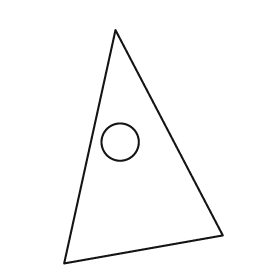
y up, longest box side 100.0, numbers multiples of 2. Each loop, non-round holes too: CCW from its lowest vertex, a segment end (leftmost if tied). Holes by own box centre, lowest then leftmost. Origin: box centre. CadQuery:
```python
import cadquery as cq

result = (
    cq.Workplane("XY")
    .moveTo(-34.0, -50.0)
    .lineTo(34.0, -38.0)
    .lineTo(-12.0, 50.0)
    .close()
    .moveTo(-10.0, 2.0)
    .circle(8.0)
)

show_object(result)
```